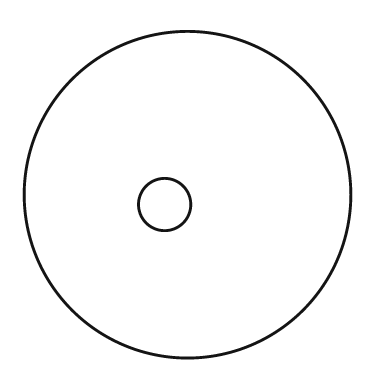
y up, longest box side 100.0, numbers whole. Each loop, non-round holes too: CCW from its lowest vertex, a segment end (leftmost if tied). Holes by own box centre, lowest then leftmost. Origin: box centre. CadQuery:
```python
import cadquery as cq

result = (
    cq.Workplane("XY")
    .moveTo(0.0, 0.0)
    .circle(50.0)
    .moveTo(-7.0, -3.0)
    .circle(8.0)
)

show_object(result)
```